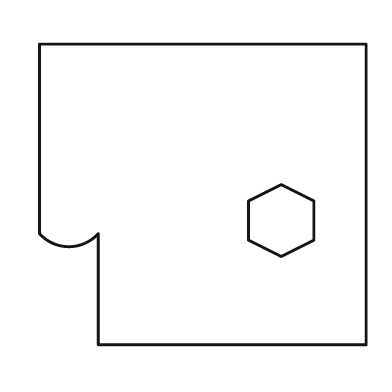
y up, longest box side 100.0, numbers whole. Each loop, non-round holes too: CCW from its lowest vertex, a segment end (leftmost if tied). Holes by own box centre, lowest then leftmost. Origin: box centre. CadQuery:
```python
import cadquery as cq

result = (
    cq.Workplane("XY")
    .moveTo(-32.0, -46.0)
    .lineTo(50.0, -46.0)
    .lineTo(50.0, 46.0)
    .lineTo(-50.0, 46.0)
    .lineTo(-50.0, -12.0)
    .threePointArc((-41.0, -16.0), (-32.0, -12.0))
    .close()
    .moveTo(24.0, -19.0)
    .lineTo(34.0, -14.0)
    .lineTo(34.0, -2.0)
    .lineTo(24.0, 3.0)
    .lineTo(14.0, -2.0)
    .lineTo(14.0, -14.0)
    .close()
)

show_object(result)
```